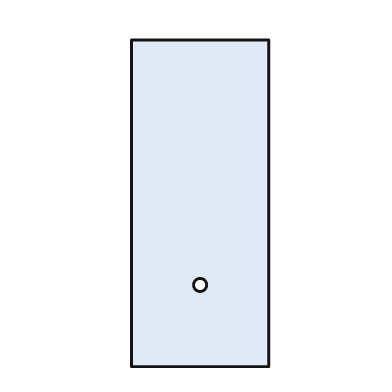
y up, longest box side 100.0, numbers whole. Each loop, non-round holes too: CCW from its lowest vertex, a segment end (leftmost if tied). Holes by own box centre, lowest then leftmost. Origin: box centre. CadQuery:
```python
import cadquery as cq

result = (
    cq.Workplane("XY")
    .moveTo(-21.0, -50.0)
    .lineTo(21.0, -50.0)
    .lineTo(21.0, 50.0)
    .lineTo(-21.0, 50.0)
    .close()
    .moveTo(0.0, -25.0)
    .circle(2.0)
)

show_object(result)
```